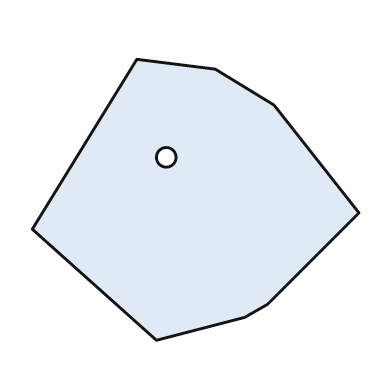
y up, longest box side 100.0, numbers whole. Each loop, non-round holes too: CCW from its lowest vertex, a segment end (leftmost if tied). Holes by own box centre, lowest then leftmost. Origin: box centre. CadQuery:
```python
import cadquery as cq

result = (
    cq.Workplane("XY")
    .moveTo(-12.0, -43.0)
    .lineTo(15.0, -36.0)
    .lineTo(22.0, -32.0)
    .lineTo(50.0, -4.0)
    .lineTo(24.0, 29.0)
    .lineTo(6.0, 40.0)
    .lineTo(-18.0, 43.0)
    .lineTo(-50.0, -9.0)
    .close()
    .moveTo(-9.0, 13.0)
    .circle(3.0)
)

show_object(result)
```